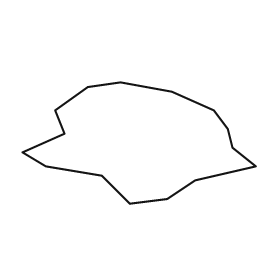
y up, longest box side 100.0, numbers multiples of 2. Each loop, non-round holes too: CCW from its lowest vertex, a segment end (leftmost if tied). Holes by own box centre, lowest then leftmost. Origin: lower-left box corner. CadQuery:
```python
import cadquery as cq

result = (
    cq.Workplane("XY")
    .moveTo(46.0, 0.0)
    .lineTo(62.0, 2.0)
    .lineTo(74.0, 10.0)
    .lineTo(100.0, 16.0)
    .lineTo(90.0, 24.0)
    .lineTo(88.0, 32.0)
    .lineTo(82.0, 40.0)
    .lineTo(64.0, 48.0)
    .lineTo(42.0, 52.0)
    .lineTo(28.0, 50.0)
    .lineTo(14.0, 40.0)
    .lineTo(18.0, 30.0)
    .lineTo(0.0, 22.0)
    .lineTo(10.0, 16.0)
    .lineTo(34.0, 12.0)
    .close()
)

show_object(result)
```